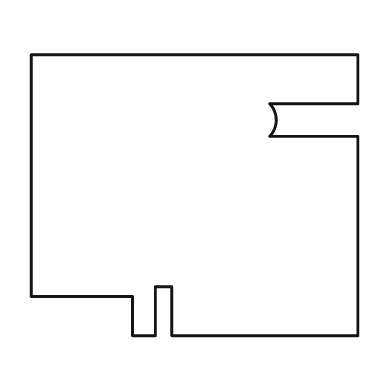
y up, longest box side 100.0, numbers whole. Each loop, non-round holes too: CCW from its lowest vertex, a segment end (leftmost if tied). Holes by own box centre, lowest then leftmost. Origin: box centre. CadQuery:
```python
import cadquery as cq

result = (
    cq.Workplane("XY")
    .moveTo(-19.0, -43.0)
    .lineTo(-12.0, -43.0)
    .lineTo(-12.0, -28.0)
    .lineTo(-7.0, -28.0)
    .lineTo(-7.0, -43.0)
    .lineTo(50.0, -43.0)
    .lineTo(50.0, 18.0)
    .lineTo(23.0, 18.0)
    .threePointArc((25.0, 23.0), (23.0, 28.0))
    .lineTo(50.0, 28.0)
    .lineTo(50.0, 43.0)
    .lineTo(-50.0, 43.0)
    .lineTo(-50.0, -31.0)
    .lineTo(-19.0, -31.0)
    .close()
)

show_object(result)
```